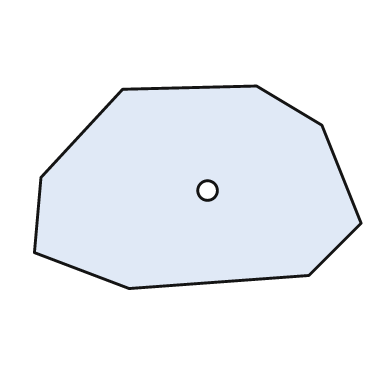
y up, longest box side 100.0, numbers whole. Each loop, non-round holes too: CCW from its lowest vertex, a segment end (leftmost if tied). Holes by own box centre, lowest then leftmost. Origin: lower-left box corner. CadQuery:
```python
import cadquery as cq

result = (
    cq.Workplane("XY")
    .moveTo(29.0, 0.0)
    .lineTo(84.0, 4.0)
    .lineTo(100.0, 20.0)
    .lineTo(88.0, 50.0)
    .lineTo(68.0, 62.0)
    .lineTo(27.0, 61.0)
    .lineTo(2.0, 34.0)
    .lineTo(0.0, 11.0)
    .close()
    .moveTo(53.0, 30.0)
    .circle(3.0)
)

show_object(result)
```